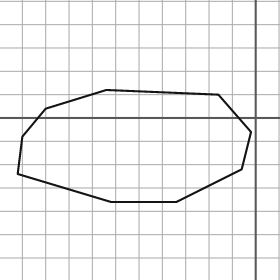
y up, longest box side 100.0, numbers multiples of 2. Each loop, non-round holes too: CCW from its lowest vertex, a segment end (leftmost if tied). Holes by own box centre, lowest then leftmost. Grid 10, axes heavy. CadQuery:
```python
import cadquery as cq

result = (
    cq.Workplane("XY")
    .moveTo(-62.0, -36.0)
    .lineTo(-34.0, -36.0)
    .lineTo(-6.0, -22.0)
    .lineTo(-2.0, -6.0)
    .lineTo(-16.0, 10.0)
    .lineTo(-64.0, 12.0)
    .lineTo(-90.0, 4.0)
    .lineTo(-100.0, -8.0)
    .lineTo(-102.0, -24.0)
    .close()
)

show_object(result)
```